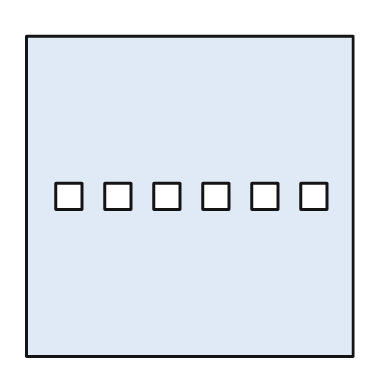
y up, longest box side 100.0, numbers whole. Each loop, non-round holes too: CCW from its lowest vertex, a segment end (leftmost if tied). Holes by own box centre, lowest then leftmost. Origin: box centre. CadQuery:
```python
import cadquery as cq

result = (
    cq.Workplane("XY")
    .moveTo(-50.0, -49.0)
    .lineTo(50.0, -49.0)
    .lineTo(50.0, 49.0)
    .lineTo(-50.0, 49.0)
    .close()
    .moveTo(-41.0, -4.0)
    .lineTo(-33.0, -4.0)
    .lineTo(-33.0, 4.0)
    .lineTo(-41.0, 4.0)
    .close()
    .moveTo(-26.0, -4.0)
    .lineTo(-18.0, -4.0)
    .lineTo(-18.0, 4.0)
    .lineTo(-26.0, 4.0)
    .close()
    .moveTo(-11.0, -4.0)
    .lineTo(-3.0, -4.0)
    .lineTo(-3.0, 4.0)
    .lineTo(-11.0, 4.0)
    .close()
    .moveTo(4.0, -4.0)
    .lineTo(12.0, -4.0)
    .lineTo(12.0, 4.0)
    .lineTo(4.0, 4.0)
    .close()
    .moveTo(19.0, -4.0)
    .lineTo(27.0, -4.0)
    .lineTo(27.0, 4.0)
    .lineTo(19.0, 4.0)
    .close()
    .moveTo(34.0, -4.0)
    .lineTo(42.0, -4.0)
    .lineTo(42.0, 4.0)
    .lineTo(34.0, 4.0)
    .close()
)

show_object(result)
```